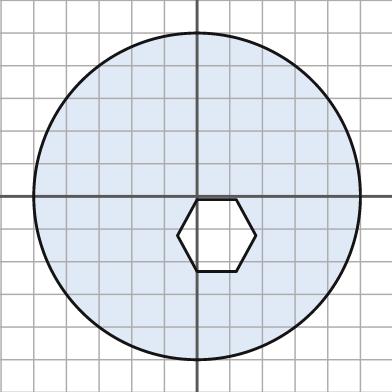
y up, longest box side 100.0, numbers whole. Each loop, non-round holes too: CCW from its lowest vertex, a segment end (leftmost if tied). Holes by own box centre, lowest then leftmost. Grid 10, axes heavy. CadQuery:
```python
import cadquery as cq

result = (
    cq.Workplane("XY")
    .moveTo(0.0, 0.0)
    .circle(50.0)
    .moveTo(0.0, -23.0)
    .lineTo(12.0, -23.0)
    .lineTo(18.0, -12.0)
    .lineTo(12.0, -1.0)
    .lineTo(0.0, -1.0)
    .lineTo(-6.0, -12.0)
    .close()
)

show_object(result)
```